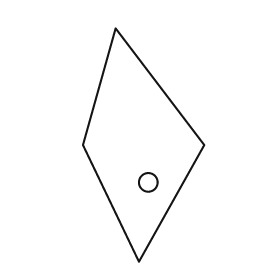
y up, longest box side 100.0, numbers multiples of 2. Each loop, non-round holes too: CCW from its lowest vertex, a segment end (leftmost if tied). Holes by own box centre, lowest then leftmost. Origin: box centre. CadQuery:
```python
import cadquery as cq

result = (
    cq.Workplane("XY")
    .moveTo(-2.0, -50.0)
    .lineTo(26.0, 0.0)
    .lineTo(-12.0, 50.0)
    .lineTo(-26.0, 0.0)
    .close()
    .moveTo(2.0, -16.0)
    .circle(4.0)
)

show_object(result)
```